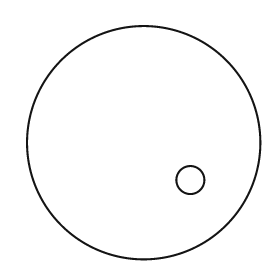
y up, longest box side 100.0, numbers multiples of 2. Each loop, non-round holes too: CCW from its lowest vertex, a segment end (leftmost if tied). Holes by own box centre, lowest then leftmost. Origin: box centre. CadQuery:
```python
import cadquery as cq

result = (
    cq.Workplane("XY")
    .moveTo(0.0, 0.0)
    .circle(50.0)
    .moveTo(20.0, -16.0)
    .circle(6.0)
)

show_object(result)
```